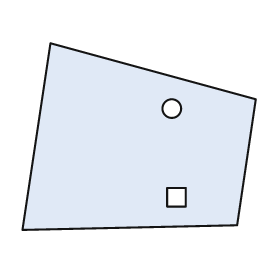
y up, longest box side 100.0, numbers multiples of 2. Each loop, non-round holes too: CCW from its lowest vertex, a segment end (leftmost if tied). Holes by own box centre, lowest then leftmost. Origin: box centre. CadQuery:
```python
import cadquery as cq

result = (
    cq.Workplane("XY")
    .moveTo(-50.0, -40.0)
    .lineTo(42.0, -38.0)
    .lineTo(50.0, 16.0)
    .lineTo(-38.0, 40.0)
    .close()
    .moveTo(12.0, -30.0)
    .lineTo(20.0, -30.0)
    .lineTo(20.0, -22.0)
    .lineTo(12.0, -22.0)
    .close()
    .moveTo(14.0, 12.0)
    .circle(4.0)
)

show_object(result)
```